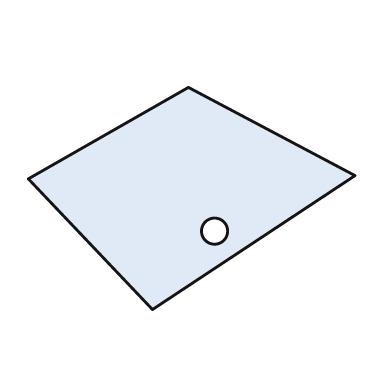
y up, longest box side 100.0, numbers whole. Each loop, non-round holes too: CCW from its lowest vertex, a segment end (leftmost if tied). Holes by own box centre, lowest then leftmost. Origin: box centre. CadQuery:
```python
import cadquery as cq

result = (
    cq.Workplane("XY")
    .moveTo(-12.0, -34.0)
    .lineTo(50.0, 7.0)
    .lineTo(-1.0, 34.0)
    .lineTo(-50.0, 6.0)
    .close()
    .moveTo(7.0, -10.0)
    .circle(4.0)
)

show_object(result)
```